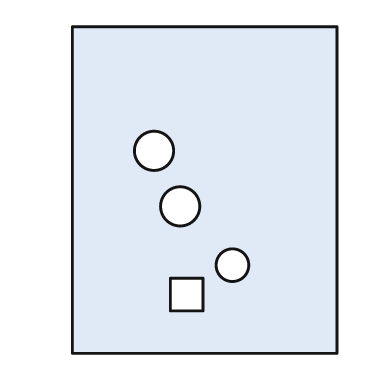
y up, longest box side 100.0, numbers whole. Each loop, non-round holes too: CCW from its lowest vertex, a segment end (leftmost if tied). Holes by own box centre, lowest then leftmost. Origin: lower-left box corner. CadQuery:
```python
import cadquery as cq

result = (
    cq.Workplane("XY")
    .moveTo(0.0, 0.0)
    .lineTo(81.0, 0.0)
    .lineTo(81.0, 100.0)
    .lineTo(0.0, 100.0)
    .close()
    .moveTo(30.0, 13.0)
    .lineTo(40.0, 13.0)
    .lineTo(40.0, 23.0)
    .lineTo(30.0, 23.0)
    .close()
    .moveTo(49.0, 27.0)
    .circle(5.0)
    .moveTo(33.0, 45.0)
    .circle(6.0)
    .moveTo(25.0, 62.0)
    .circle(6.0)
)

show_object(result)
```